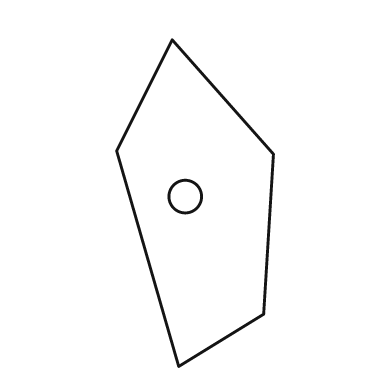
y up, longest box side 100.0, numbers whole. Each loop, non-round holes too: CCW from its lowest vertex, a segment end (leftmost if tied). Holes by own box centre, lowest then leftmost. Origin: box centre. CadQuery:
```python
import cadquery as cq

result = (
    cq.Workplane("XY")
    .moveTo(-5.0, -50.0)
    .lineTo(21.0, -34.0)
    .lineTo(24.0, 15.0)
    .lineTo(-7.0, 50.0)
    .lineTo(-24.0, 16.0)
    .close()
    .moveTo(-3.0, 2.0)
    .circle(5.0)
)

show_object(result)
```